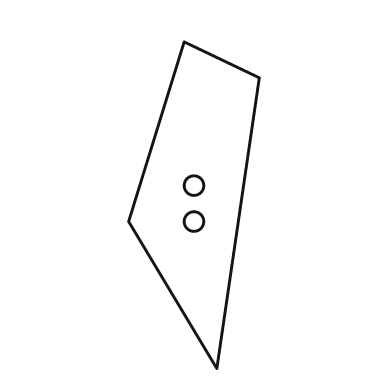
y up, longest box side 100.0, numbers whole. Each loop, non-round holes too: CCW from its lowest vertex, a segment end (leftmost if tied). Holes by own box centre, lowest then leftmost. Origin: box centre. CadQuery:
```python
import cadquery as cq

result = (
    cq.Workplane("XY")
    .moveTo(7.0, -50.0)
    .lineTo(20.0, 39.0)
    .lineTo(-3.0, 50.0)
    .lineTo(-20.0, -5.0)
    .close()
    .moveTo(0.0, -5.0)
    .circle(3.0)
    .moveTo(0.0, 6.0)
    .circle(3.0)
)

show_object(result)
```